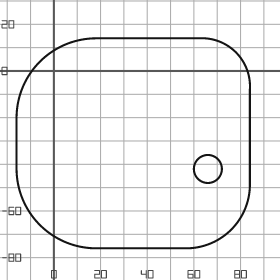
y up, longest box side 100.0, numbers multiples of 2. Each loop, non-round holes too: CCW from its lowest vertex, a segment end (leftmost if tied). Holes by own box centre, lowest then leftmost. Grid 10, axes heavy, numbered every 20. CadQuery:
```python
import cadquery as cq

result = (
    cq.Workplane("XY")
    .moveTo(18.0, -76.0)
    .lineTo(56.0, -76.0)
    .threePointArc((76.0, -68.0), (84.0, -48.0))
    .lineTo(84.0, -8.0)
    .threePointArc((78.0, 8.0), (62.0, 14.0))
    .lineTo(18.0, 14.0)
    .threePointArc((-6.0, 4.0), (-16.0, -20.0))
    .lineTo(-16.0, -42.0)
    .threePointArc((-6.0, -66.0), (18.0, -76.0))
    .close()
    .moveTo(66.0, -42.0)
    .circle(6.0)
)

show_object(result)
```